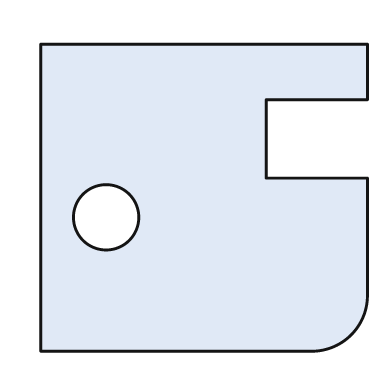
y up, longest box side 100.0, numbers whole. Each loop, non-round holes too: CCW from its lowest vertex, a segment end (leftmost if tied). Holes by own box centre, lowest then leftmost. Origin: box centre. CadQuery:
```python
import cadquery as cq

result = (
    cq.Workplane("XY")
    .moveTo(-50.0, -47.0)
    .lineTo(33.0, -47.0)
    .threePointArc((45.0, -42.0), (50.0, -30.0))
    .lineTo(50.0, 6.0)
    .lineTo(19.0, 6.0)
    .lineTo(19.0, 30.0)
    .lineTo(50.0, 30.0)
    .lineTo(50.0, 47.0)
    .lineTo(-50.0, 47.0)
    .close()
    .moveTo(-30.0, -6.0)
    .circle(10.0)
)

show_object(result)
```